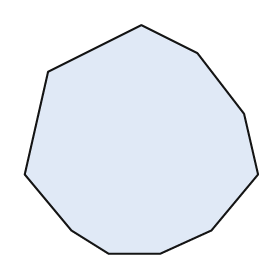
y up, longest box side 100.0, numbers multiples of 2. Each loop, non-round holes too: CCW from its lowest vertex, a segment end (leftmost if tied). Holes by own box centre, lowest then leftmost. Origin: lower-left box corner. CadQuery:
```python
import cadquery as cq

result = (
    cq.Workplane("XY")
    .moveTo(36.0, 0.0)
    .lineTo(58.0, 0.0)
    .lineTo(80.0, 10.0)
    .lineTo(100.0, 34.0)
    .lineTo(94.0, 60.0)
    .lineTo(74.0, 86.0)
    .lineTo(50.0, 98.0)
    .lineTo(10.0, 78.0)
    .lineTo(0.0, 34.0)
    .lineTo(20.0, 10.0)
    .close()
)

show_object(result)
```